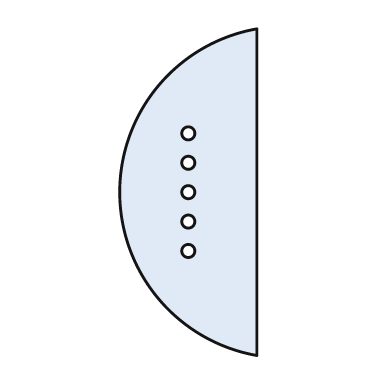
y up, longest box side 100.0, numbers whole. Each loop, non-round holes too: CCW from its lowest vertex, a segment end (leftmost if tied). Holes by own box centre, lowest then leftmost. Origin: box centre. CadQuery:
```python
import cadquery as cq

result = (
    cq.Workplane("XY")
    .moveTo(21.0, -50.0)
    .lineTo(21.0, 50.0)
    .threePointArc((-21.0, 0.0), (21.0, -50.0))
    .close()
    .moveTo(0.0, -18.0)
    .circle(2.0)
    .moveTo(0.0, -9.0)
    .circle(2.0)
    .moveTo(0.0, 0.0)
    .circle(2.0)
    .moveTo(0.0, 9.0)
    .circle(2.0)
    .moveTo(0.0, 18.0)
    .circle(2.0)
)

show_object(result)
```